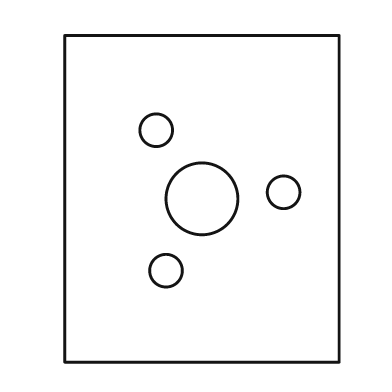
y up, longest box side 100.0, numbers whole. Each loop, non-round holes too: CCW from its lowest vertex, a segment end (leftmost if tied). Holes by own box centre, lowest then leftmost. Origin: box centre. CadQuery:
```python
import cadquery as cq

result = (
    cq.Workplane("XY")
    .moveTo(-42.0, -50.0)
    .lineTo(42.0, -50.0)
    .lineTo(42.0, 50.0)
    .lineTo(-42.0, 50.0)
    .close()
    .moveTo(-11.0, -22.0)
    .circle(5.0)
    .moveTo(0.0, 0.0)
    .circle(11.0)
    .moveTo(25.0, 2.0)
    .circle(5.0)
    .moveTo(-14.0, 21.0)
    .circle(5.0)
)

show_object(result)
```